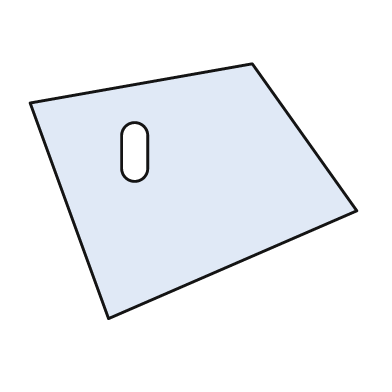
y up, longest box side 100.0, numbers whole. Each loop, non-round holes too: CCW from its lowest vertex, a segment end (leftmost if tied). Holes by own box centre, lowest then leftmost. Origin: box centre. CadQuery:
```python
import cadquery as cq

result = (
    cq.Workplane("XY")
    .moveTo(-26.0, -39.0)
    .lineTo(50.0, -6.0)
    .lineTo(18.0, 39.0)
    .lineTo(-50.0, 27.0)
    .close()
    .moveTo(-22.0, 7.0)
    .threePointArc((-18.0, 3.0), (-14.0, 7.0))
    .lineTo(-14.0, 17.0)
    .threePointArc((-18.0, 21.0), (-22.0, 17.0))
    .close()
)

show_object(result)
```